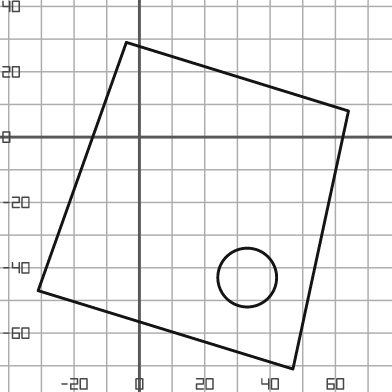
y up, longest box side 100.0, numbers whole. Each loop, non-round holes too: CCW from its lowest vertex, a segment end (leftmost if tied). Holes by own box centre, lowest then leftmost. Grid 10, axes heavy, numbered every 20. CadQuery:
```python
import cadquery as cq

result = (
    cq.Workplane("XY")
    .moveTo(47.0, -71.0)
    .lineTo(64.0, 8.0)
    .lineTo(-4.0, 29.0)
    .lineTo(-31.0, -47.0)
    .close()
    .moveTo(33.0, -43.0)
    .circle(9.0)
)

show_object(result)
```